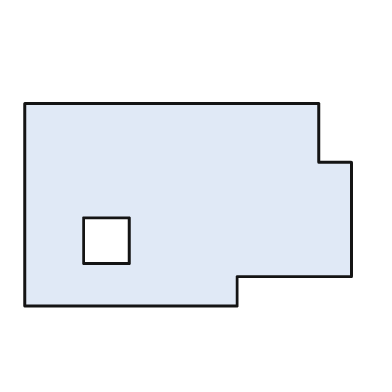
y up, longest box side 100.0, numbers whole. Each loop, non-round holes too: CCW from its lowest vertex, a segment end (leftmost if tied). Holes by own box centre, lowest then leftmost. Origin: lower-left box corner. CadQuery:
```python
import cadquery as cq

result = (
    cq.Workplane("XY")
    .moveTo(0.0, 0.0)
    .lineTo(65.0, 0.0)
    .lineTo(65.0, 9.0)
    .lineTo(100.0, 9.0)
    .lineTo(100.0, 44.0)
    .lineTo(90.0, 44.0)
    .lineTo(90.0, 62.0)
    .lineTo(0.0, 62.0)
    .close()
    .moveTo(18.0, 13.0)
    .lineTo(32.0, 13.0)
    .lineTo(32.0, 27.0)
    .lineTo(18.0, 27.0)
    .close()
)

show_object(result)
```